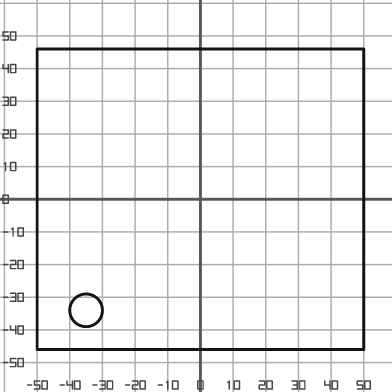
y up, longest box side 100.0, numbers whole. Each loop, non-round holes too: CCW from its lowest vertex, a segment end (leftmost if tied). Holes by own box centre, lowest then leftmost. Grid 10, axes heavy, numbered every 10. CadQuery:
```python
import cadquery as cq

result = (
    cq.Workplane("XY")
    .moveTo(-50.0, -46.0)
    .lineTo(50.0, -46.0)
    .lineTo(50.0, 46.0)
    .lineTo(-50.0, 46.0)
    .close()
    .moveTo(-35.0, -34.0)
    .circle(5.0)
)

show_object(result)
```